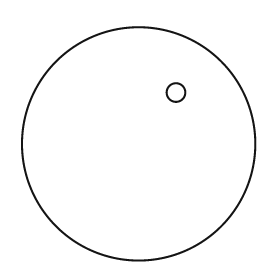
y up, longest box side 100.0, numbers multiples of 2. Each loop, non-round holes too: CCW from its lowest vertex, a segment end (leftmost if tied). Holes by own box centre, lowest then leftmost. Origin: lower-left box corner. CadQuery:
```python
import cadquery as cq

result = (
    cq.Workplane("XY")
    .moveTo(50.0, 50.0)
    .circle(50.0)
    .moveTo(66.0, 72.0)
    .circle(4.0)
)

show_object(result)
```